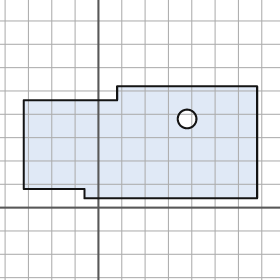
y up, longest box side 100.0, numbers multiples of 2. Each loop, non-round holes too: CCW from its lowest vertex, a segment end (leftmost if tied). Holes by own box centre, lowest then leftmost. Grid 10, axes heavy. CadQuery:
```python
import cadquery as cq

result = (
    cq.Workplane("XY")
    .moveTo(-6.0, 4.0)
    .lineTo(68.0, 4.0)
    .lineTo(68.0, 52.0)
    .lineTo(8.0, 52.0)
    .lineTo(8.0, 46.0)
    .lineTo(-32.0, 46.0)
    .lineTo(-32.0, 8.0)
    .lineTo(-6.0, 8.0)
    .close()
    .moveTo(38.0, 38.0)
    .circle(4.0)
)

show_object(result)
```